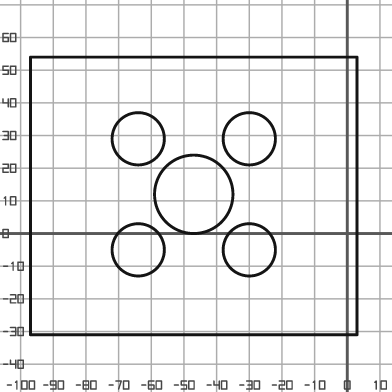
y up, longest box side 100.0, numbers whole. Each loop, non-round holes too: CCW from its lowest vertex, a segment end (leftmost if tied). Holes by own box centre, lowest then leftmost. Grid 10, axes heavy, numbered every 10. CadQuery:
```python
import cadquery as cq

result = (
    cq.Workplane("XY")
    .moveTo(-97.0, -31.0)
    .lineTo(3.0, -31.0)
    .lineTo(3.0, 54.0)
    .lineTo(-97.0, 54.0)
    .close()
    .moveTo(-64.0, -5.0)
    .circle(8.0)
    .moveTo(-30.0, -5.0)
    .circle(8.0)
    .moveTo(-47.0, 12.0)
    .circle(12.0)
    .moveTo(-64.0, 29.0)
    .circle(8.0)
    .moveTo(-30.0, 29.0)
    .circle(8.0)
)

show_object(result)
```